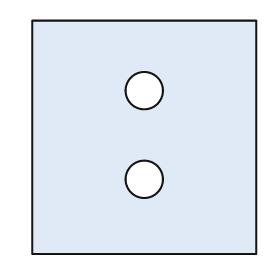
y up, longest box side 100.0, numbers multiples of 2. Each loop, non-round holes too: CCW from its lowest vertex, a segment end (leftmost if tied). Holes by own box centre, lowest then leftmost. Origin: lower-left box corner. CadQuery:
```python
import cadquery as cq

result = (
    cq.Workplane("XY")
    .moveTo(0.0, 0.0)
    .lineTo(96.0, 0.0)
    .lineTo(96.0, 100.0)
    .lineTo(0.0, 100.0)
    .close()
    .moveTo(48.0, 32.0)
    .circle(8.0)
    .moveTo(48.0, 70.0)
    .circle(8.0)
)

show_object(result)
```